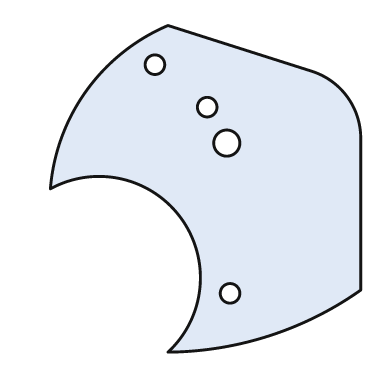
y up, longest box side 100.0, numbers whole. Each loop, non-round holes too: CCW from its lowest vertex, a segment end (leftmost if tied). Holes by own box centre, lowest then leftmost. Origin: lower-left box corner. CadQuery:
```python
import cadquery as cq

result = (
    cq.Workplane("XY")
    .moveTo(36.0, 0.0)
    .threePointArc((67.0, 5.0), (95.0, 19.0))
    .lineTo(95.0, 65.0)
    .threePointArc((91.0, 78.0), (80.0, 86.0))
    .lineTo(36.0, 100.0)
    .threePointArc((11.0, 80.0), (0.0, 50.0))
    .threePointArc((40.0, 41.0), (36.0, 0.0))
    .close()
    .moveTo(55.0, 18.0)
    .circle(3.0)
    .moveTo(54.0, 64.0)
    .circle(4.0)
    .moveTo(48.0, 75.0)
    .circle(3.0)
    .moveTo(32.0, 88.0)
    .circle(3.0)
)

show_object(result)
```